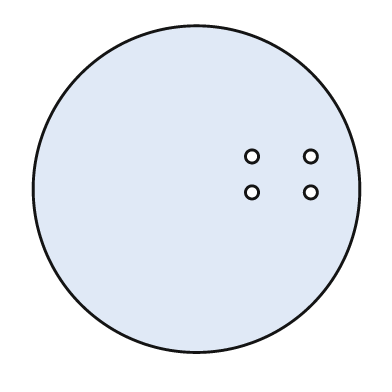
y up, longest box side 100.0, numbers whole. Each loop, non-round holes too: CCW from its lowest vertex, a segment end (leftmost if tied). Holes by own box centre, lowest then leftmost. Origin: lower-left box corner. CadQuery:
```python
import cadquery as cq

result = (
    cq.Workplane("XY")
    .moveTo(50.0, 50.0)
    .circle(50.0)
    .moveTo(67.0, 49.0)
    .circle(2.0)
    .moveTo(85.0, 49.0)
    .circle(2.0)
    .moveTo(67.0, 60.0)
    .circle(2.0)
    .moveTo(85.0, 60.0)
    .circle(2.0)
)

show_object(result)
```